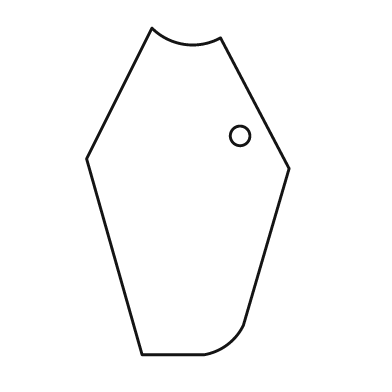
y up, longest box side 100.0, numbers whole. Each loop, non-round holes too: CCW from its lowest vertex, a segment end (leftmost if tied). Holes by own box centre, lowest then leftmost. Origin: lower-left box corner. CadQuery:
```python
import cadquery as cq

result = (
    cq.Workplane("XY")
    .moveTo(17.0, 0.0)
    .lineTo(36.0, 0.0)
    .threePointArc((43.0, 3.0), (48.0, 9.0))
    .lineTo(62.0, 57.0)
    .lineTo(41.0, 97.0)
    .threePointArc((30.0, 95.0), (20.0, 100.0))
    .lineTo(0.0, 60.0)
    .close()
    .moveTo(47.0, 67.0)
    .circle(3.0)
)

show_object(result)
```